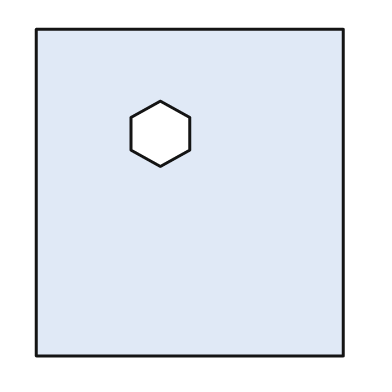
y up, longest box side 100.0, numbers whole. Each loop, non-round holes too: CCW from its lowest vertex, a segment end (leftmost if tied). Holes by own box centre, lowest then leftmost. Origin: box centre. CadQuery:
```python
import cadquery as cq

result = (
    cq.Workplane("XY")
    .moveTo(-47.0, -50.0)
    .lineTo(47.0, -50.0)
    .lineTo(47.0, 50.0)
    .lineTo(-47.0, 50.0)
    .close()
    .moveTo(-9.0, 8.0)
    .lineTo(0.0, 13.0)
    .lineTo(0.0, 23.0)
    .lineTo(-9.0, 28.0)
    .lineTo(-18.0, 23.0)
    .lineTo(-18.0, 13.0)
    .close()
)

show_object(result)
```